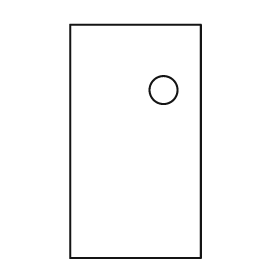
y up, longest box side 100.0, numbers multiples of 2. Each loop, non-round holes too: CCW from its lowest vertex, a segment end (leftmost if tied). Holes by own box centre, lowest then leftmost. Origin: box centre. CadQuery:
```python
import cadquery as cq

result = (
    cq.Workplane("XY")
    .moveTo(-28.0, -50.0)
    .lineTo(28.0, -50.0)
    .lineTo(28.0, 50.0)
    .lineTo(-28.0, 50.0)
    .close()
    .moveTo(12.0, 22.0)
    .circle(6.0)
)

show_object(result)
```